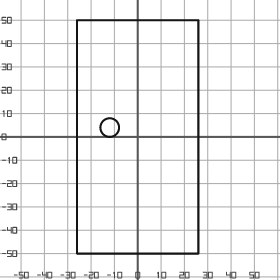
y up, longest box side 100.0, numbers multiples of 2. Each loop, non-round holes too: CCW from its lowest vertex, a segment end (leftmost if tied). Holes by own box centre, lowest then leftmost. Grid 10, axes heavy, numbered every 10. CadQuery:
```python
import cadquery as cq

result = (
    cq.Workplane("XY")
    .moveTo(-26.0, -50.0)
    .lineTo(26.0, -50.0)
    .lineTo(26.0, 50.0)
    .lineTo(-26.0, 50.0)
    .close()
    .moveTo(-12.0, 4.0)
    .circle(4.0)
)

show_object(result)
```